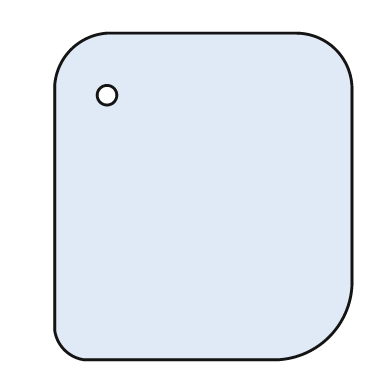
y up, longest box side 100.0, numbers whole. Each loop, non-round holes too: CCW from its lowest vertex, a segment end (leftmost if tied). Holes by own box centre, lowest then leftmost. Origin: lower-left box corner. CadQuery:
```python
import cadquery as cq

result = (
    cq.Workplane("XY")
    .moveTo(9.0, 0.0)
    .lineTo(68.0, 0.0)
    .threePointArc((84.0, 7.0), (91.0, 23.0))
    .lineTo(91.0, 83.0)
    .threePointArc((86.0, 95.0), (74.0, 100.0))
    .lineTo(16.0, 100.0)
    .threePointArc((5.0, 95.0), (0.0, 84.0))
    .lineTo(0.0, 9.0)
    .threePointArc((3.0, 3.0), (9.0, 0.0))
    .close()
    .moveTo(16.0, 81.0)
    .circle(3.0)
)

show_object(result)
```